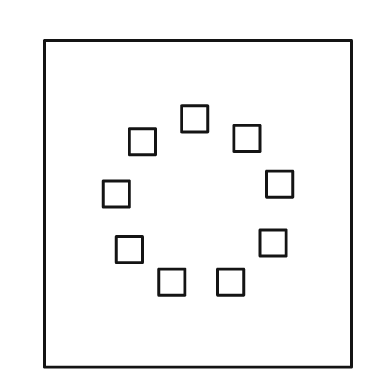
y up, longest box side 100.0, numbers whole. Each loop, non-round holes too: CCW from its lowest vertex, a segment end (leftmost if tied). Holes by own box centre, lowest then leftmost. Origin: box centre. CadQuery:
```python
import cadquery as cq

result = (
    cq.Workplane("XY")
    .moveTo(-47.0, -50.0)
    .lineTo(47.0, -50.0)
    .lineTo(47.0, 50.0)
    .lineTo(-47.0, 50.0)
    .close()
    .moveTo(-12.0, -28.0)
    .lineTo(-4.0, -28.0)
    .lineTo(-4.0, -20.0)
    .lineTo(-12.0, -20.0)
    .close()
    .moveTo(6.0, -28.0)
    .lineTo(14.0, -28.0)
    .lineTo(14.0, -20.0)
    .lineTo(6.0, -20.0)
    .close()
    .moveTo(-25.0, -18.0)
    .lineTo(-17.0, -18.0)
    .lineTo(-17.0, -10.0)
    .lineTo(-25.0, -10.0)
    .close()
    .moveTo(19.0, -16.0)
    .lineTo(27.0, -16.0)
    .lineTo(27.0, -8.0)
    .lineTo(19.0, -8.0)
    .close()
    .moveTo(-29.0, -1.0)
    .lineTo(-21.0, -1.0)
    .lineTo(-21.0, 7.0)
    .lineTo(-29.0, 7.0)
    .close()
    .moveTo(21.0, 2.0)
    .lineTo(29.0, 2.0)
    .lineTo(29.0, 10.0)
    .lineTo(21.0, 10.0)
    .close()
    .moveTo(-21.0, 15.0)
    .lineTo(-13.0, 15.0)
    .lineTo(-13.0, 23.0)
    .lineTo(-21.0, 23.0)
    .close()
    .moveTo(11.0, 16.0)
    .lineTo(19.0, 16.0)
    .lineTo(19.0, 24.0)
    .lineTo(11.0, 24.0)
    .close()
    .moveTo(-5.0, 22.0)
    .lineTo(3.0, 22.0)
    .lineTo(3.0, 30.0)
    .lineTo(-5.0, 30.0)
    .close()
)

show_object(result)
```